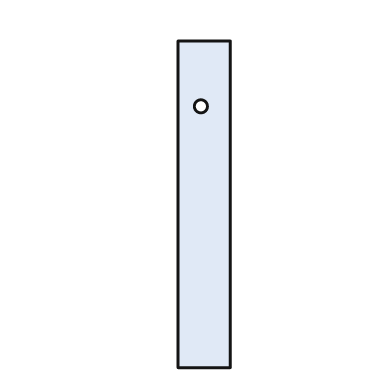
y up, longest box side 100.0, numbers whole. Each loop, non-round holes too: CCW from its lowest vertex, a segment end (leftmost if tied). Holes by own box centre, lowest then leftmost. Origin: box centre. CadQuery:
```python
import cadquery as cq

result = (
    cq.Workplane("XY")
    .moveTo(-8.0, -50.0)
    .lineTo(8.0, -50.0)
    .lineTo(8.0, 50.0)
    .lineTo(-8.0, 50.0)
    .close()
    .moveTo(-1.0, 30.0)
    .circle(2.0)
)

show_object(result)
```